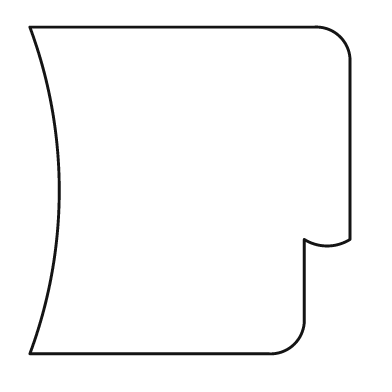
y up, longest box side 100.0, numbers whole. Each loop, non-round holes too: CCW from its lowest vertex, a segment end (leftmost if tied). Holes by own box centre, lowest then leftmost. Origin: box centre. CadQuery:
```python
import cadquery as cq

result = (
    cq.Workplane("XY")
    .moveTo(-49.0, -50.0)
    .lineTo(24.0, -50.0)
    .threePointArc((32.0, -47.0), (35.0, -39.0))
    .lineTo(35.0, -15.0)
    .threePointArc((42.0, -17.0), (49.0, -15.0))
    .lineTo(49.0, 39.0)
    .threePointArc((46.0, 47.0), (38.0, 50.0))
    .lineTo(-49.0, 50.0)
    .threePointArc((-40.0, 0.0), (-49.0, -50.0))
    .close()
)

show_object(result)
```